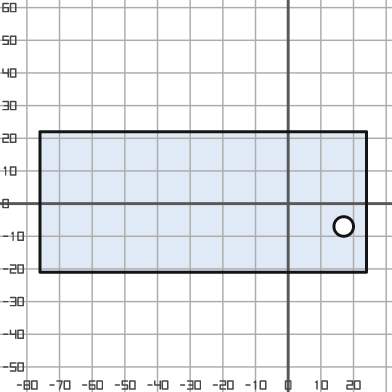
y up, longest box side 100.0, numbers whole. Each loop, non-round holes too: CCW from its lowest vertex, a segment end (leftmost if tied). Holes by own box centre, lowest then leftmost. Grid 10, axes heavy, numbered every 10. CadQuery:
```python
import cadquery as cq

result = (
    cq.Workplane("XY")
    .moveTo(-76.0, -21.0)
    .lineTo(24.0, -21.0)
    .lineTo(24.0, 22.0)
    .lineTo(-76.0, 22.0)
    .close()
    .moveTo(17.0, -7.0)
    .circle(3.0)
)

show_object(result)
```